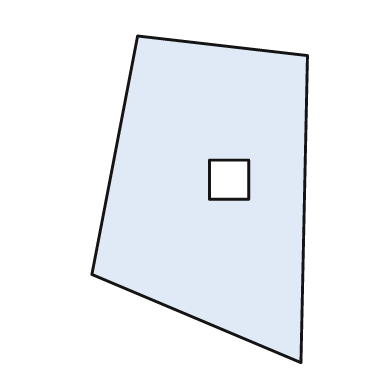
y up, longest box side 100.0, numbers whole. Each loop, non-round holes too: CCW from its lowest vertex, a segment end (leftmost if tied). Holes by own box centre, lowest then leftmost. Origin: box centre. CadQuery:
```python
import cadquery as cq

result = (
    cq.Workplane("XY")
    .moveTo(31.0, -50.0)
    .lineTo(33.0, 44.0)
    .lineTo(-19.0, 50.0)
    .lineTo(-33.0, -23.0)
    .close()
    .moveTo(3.0, 0.0)
    .lineTo(15.0, 0.0)
    .lineTo(15.0, 12.0)
    .lineTo(3.0, 12.0)
    .close()
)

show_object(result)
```